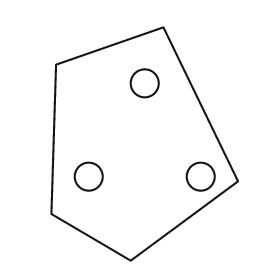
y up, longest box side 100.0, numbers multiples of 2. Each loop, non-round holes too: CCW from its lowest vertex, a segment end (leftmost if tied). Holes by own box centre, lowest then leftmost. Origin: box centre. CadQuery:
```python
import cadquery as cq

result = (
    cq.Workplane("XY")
    .moveTo(-6.0, -50.0)
    .lineTo(40.0, -16.0)
    .lineTo(8.0, 50.0)
    .lineTo(-38.0, 34.0)
    .lineTo(-40.0, -30.0)
    .close()
    .moveTo(-24.0, -14.0)
    .circle(6.0)
    .moveTo(24.0, -14.0)
    .circle(6.0)
    .moveTo(0.0, 26.0)
    .circle(6.0)
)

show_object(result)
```